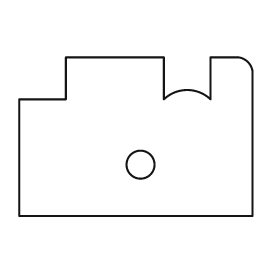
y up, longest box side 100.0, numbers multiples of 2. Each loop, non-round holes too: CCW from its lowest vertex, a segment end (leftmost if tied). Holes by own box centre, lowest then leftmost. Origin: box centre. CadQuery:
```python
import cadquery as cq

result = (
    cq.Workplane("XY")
    .moveTo(-50.0, -34.0)
    .lineTo(50.0, -34.0)
    .lineTo(50.0, 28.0)
    .threePointArc((48.0, 32.0), (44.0, 34.0))
    .lineTo(32.0, 34.0)
    .lineTo(32.0, 16.0)
    .threePointArc((22.0, 20.0), (12.0, 16.0))
    .lineTo(12.0, 34.0)
    .lineTo(-30.0, 34.0)
    .lineTo(-30.0, 16.0)
    .lineTo(-50.0, 16.0)
    .close()
    .moveTo(2.0, -12.0)
    .circle(6.0)
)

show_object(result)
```